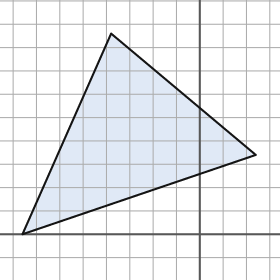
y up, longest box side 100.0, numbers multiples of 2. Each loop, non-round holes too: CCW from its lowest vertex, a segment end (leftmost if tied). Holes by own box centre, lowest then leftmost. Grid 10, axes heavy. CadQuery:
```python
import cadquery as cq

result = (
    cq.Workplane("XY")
    .moveTo(-76.0, 0.0)
    .lineTo(24.0, 34.0)
    .lineTo(-38.0, 86.0)
    .close()
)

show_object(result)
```